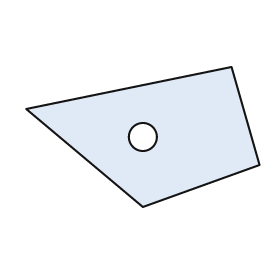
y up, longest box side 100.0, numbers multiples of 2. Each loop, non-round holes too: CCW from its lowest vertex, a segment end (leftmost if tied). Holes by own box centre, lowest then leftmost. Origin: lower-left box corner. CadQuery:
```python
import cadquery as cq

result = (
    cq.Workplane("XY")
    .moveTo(50.0, 0.0)
    .lineTo(100.0, 18.0)
    .lineTo(88.0, 60.0)
    .lineTo(0.0, 42.0)
    .close()
    .moveTo(50.0, 30.0)
    .circle(6.0)
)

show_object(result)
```